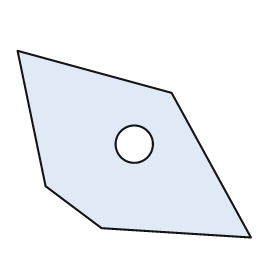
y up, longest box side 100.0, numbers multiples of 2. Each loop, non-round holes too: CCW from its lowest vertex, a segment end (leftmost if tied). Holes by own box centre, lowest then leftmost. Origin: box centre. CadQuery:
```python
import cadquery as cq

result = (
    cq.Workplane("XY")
    .moveTo(50.0, -40.0)
    .lineTo(16.0, 22.0)
    .lineTo(-50.0, 40.0)
    .lineTo(-38.0, -18.0)
    .lineTo(-14.0, -36.0)
    .close()
    .moveTo(0.0, 0.0)
    .circle(8.0)
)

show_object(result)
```